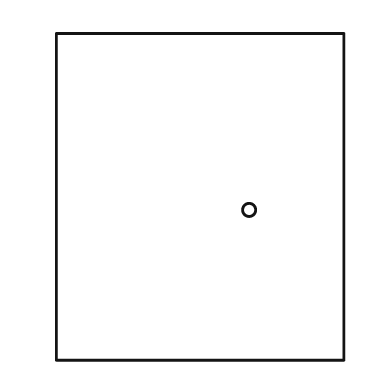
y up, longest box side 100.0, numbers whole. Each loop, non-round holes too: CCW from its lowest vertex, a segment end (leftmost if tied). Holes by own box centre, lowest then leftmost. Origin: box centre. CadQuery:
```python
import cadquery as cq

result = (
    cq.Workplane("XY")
    .moveTo(-44.0, -50.0)
    .lineTo(44.0, -50.0)
    .lineTo(44.0, 50.0)
    .lineTo(-44.0, 50.0)
    .close()
    .moveTo(15.0, -4.0)
    .circle(2.0)
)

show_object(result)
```